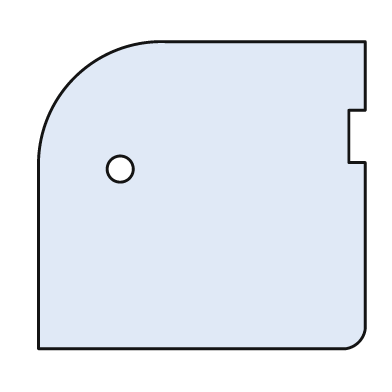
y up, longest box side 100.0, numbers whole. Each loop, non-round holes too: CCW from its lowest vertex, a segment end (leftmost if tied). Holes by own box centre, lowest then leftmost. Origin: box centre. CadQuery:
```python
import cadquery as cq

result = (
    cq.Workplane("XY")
    .moveTo(-50.0, -47.0)
    .lineTo(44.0, -47.0)
    .threePointArc((48.0, -45.0), (50.0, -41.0))
    .lineTo(50.0, 10.0)
    .lineTo(45.0, 10.0)
    .lineTo(45.0, 26.0)
    .lineTo(50.0, 26.0)
    .lineTo(50.0, 47.0)
    .lineTo(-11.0, 47.0)
    .threePointArc((-39.0, 36.0), (-50.0, 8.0))
    .close()
    .moveTo(-25.0, 8.0)
    .circle(4.0)
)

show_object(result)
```